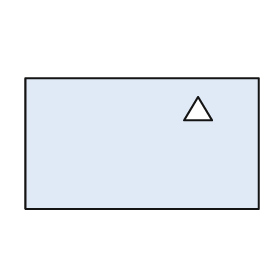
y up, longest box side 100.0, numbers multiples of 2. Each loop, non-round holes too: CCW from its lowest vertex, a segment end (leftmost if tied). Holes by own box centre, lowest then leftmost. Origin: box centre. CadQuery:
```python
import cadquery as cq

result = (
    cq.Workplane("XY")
    .moveTo(-50.0, -28.0)
    .lineTo(50.0, -28.0)
    .lineTo(50.0, 28.0)
    .lineTo(-50.0, 28.0)
    .close()
    .moveTo(18.0, 10.0)
    .lineTo(30.0, 10.0)
    .lineTo(24.0, 20.0)
    .close()
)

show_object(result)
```